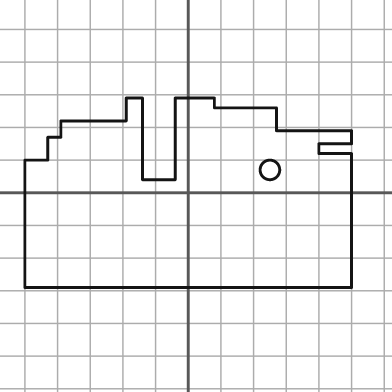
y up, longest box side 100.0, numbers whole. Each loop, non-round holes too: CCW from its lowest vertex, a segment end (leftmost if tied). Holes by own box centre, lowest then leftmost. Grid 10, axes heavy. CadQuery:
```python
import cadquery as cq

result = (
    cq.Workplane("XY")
    .moveTo(-50.0, -29.0)
    .lineTo(50.0, -29.0)
    .lineTo(50.0, 12.0)
    .lineTo(40.0, 12.0)
    .lineTo(40.0, 15.0)
    .lineTo(50.0, 15.0)
    .lineTo(50.0, 19.0)
    .lineTo(27.0, 19.0)
    .lineTo(27.0, 26.0)
    .lineTo(8.0, 26.0)
    .lineTo(8.0, 29.0)
    .lineTo(-4.0, 29.0)
    .lineTo(-4.0, 4.0)
    .lineTo(-14.0, 4.0)
    .lineTo(-14.0, 29.0)
    .lineTo(-19.0, 29.0)
    .lineTo(-19.0, 22.0)
    .lineTo(-39.0, 22.0)
    .lineTo(-39.0, 17.0)
    .lineTo(-43.0, 17.0)
    .lineTo(-43.0, 10.0)
    .lineTo(-50.0, 10.0)
    .close()
    .moveTo(25.0, 7.0)
    .circle(3.0)
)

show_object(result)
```